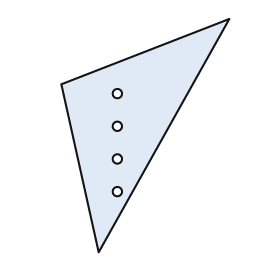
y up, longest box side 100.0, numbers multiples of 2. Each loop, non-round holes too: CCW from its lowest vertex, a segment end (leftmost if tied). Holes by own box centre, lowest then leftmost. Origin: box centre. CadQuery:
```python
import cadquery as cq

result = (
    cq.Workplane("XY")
    .moveTo(-20.0, -50.0)
    .lineTo(36.0, 50.0)
    .lineTo(-36.0, 22.0)
    .close()
    .moveTo(-12.0, -24.0)
    .circle(2.0)
    .moveTo(-12.0, -10.0)
    .circle(2.0)
    .moveTo(-12.0, 4.0)
    .circle(2.0)
    .moveTo(-12.0, 18.0)
    .circle(2.0)
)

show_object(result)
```